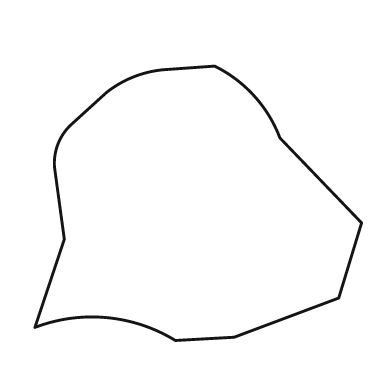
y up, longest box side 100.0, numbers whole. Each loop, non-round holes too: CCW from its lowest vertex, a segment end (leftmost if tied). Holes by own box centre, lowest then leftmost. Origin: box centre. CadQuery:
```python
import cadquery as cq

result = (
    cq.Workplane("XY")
    .moveTo(-7.0, -42.0)
    .lineTo(11.0, -41.0)
    .lineTo(43.0, -29.0)
    .lineTo(50.0, -6.0)
    .lineTo(25.0, 20.0)
    .threePointArc((17.0, 33.0), (5.0, 42.0))
    .lineTo(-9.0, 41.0)
    .threePointArc((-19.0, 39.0), (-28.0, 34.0))
    .lineTo(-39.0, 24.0)
    .threePointArc((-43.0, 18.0), (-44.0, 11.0))
    .lineTo(-41.0, -11.0)
    .lineTo(-50.0, -38.0)
    .threePointArc((-28.0, -35.0), (-7.0, -42.0))
    .close()
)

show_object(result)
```